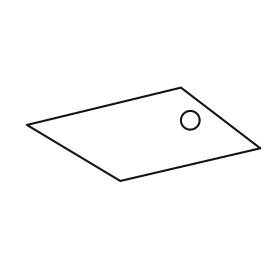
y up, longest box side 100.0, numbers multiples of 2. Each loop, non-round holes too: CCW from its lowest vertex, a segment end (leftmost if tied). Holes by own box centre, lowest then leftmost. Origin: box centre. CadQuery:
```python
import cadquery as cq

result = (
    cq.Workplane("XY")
    .moveTo(-10.0, -20.0)
    .lineTo(50.0, -6.0)
    .lineTo(16.0, 20.0)
    .lineTo(-50.0, 4.0)
    .close()
    .moveTo(20.0, 6.0)
    .circle(4.0)
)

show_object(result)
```